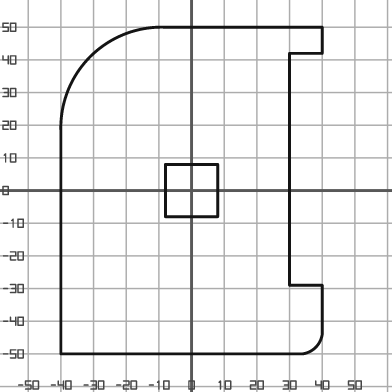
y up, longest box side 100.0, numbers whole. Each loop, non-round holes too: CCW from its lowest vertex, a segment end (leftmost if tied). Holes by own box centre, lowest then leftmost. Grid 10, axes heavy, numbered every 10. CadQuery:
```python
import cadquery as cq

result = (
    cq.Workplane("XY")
    .moveTo(-40.0, -50.0)
    .lineTo(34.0, -50.0)
    .threePointArc((38.0, -48.0), (40.0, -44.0))
    .lineTo(40.0, -29.0)
    .lineTo(30.0, -29.0)
    .lineTo(30.0, 42.0)
    .lineTo(40.0, 42.0)
    .lineTo(40.0, 50.0)
    .lineTo(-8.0, 50.0)
    .threePointArc((-31.0, 41.0), (-40.0, 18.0))
    .close()
    .moveTo(-8.0, -8.0)
    .lineTo(8.0, -8.0)
    .lineTo(8.0, 8.0)
    .lineTo(-8.0, 8.0)
    .close()
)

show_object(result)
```